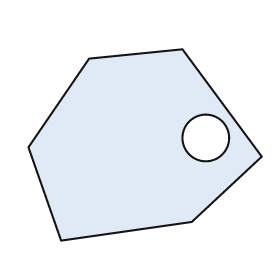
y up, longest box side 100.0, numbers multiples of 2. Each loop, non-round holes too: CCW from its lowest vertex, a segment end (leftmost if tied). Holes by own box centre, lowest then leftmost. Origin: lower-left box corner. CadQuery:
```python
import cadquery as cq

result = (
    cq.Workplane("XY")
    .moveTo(14.0, 0.0)
    .lineTo(70.0, 8.0)
    .lineTo(100.0, 36.0)
    .lineTo(66.0, 82.0)
    .lineTo(26.0, 78.0)
    .lineTo(0.0, 40.0)
    .close()
    .moveTo(76.0, 44.0)
    .circle(10.0)
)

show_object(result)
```